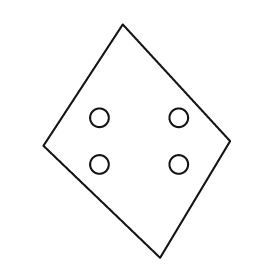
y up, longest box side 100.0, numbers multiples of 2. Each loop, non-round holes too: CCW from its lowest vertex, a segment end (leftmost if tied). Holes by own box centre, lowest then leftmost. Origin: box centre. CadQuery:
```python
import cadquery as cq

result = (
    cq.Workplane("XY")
    .moveTo(10.0, -50.0)
    .lineTo(40.0, 0.0)
    .lineTo(-6.0, 50.0)
    .lineTo(-40.0, -2.0)
    .close()
    .moveTo(-16.0, -10.0)
    .circle(4.0)
    .moveTo(18.0, -10.0)
    .circle(4.0)
    .moveTo(-16.0, 10.0)
    .circle(4.0)
    .moveTo(18.0, 10.0)
    .circle(4.0)
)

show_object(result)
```